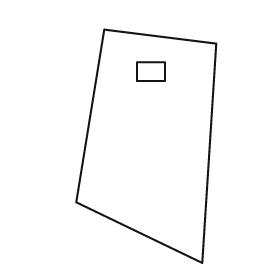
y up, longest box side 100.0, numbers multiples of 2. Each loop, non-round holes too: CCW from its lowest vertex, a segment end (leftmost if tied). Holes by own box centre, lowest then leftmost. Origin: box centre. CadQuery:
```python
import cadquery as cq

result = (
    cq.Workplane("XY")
    .moveTo(24.0, -50.0)
    .lineTo(30.0, 44.0)
    .lineTo(-18.0, 50.0)
    .lineTo(-30.0, -24.0)
    .close()
    .moveTo(-4.0, 28.0)
    .lineTo(8.0, 28.0)
    .lineTo(8.0, 36.0)
    .lineTo(-4.0, 36.0)
    .close()
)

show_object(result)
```